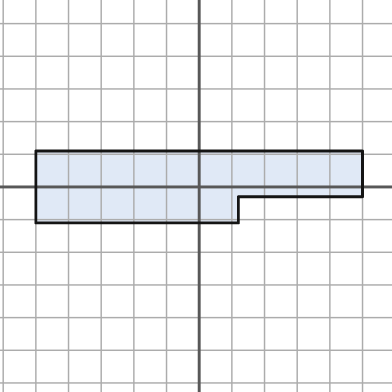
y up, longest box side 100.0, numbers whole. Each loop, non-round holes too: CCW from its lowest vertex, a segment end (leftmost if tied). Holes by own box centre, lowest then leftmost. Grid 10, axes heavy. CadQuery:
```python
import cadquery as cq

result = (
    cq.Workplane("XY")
    .moveTo(-50.0, -11.0)
    .lineTo(12.0, -11.0)
    .lineTo(12.0, -3.0)
    .lineTo(50.0, -3.0)
    .lineTo(50.0, 11.0)
    .lineTo(-50.0, 11.0)
    .close()
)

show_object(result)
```